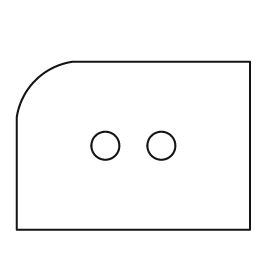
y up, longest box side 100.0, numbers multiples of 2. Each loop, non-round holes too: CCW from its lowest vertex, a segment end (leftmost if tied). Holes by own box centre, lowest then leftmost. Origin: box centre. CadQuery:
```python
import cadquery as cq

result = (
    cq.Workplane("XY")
    .moveTo(-50.0, -36.0)
    .lineTo(50.0, -36.0)
    .lineTo(50.0, 36.0)
    .lineTo(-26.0, 36.0)
    .threePointArc((-42.0, 28.0), (-50.0, 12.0))
    .close()
    .moveTo(-12.0, 0.0)
    .circle(6.0)
    .moveTo(12.0, 0.0)
    .circle(6.0)
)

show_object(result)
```